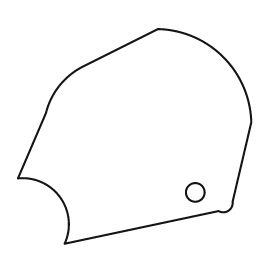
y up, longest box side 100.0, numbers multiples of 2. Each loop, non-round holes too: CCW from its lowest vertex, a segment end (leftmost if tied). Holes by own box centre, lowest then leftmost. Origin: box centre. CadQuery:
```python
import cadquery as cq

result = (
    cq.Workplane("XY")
    .moveTo(-30.0, -46.0)
    .lineTo(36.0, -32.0)
    .threePointArc((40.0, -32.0), (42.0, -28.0))
    .lineTo(50.0, 6.0)
    .threePointArc((38.0, 34.0), (10.0, 46.0))
    .lineTo(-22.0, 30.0)
    .threePointArc((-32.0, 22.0), (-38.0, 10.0))
    .lineTo(-50.0, -18.0)
    .threePointArc((-32.0, -26.0), (-30.0, -46.0))
    .close()
    .moveTo(26.0, -24.0)
    .circle(4.0)
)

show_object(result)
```